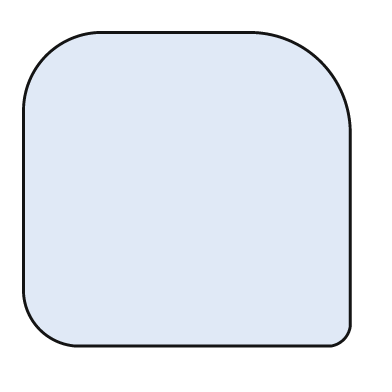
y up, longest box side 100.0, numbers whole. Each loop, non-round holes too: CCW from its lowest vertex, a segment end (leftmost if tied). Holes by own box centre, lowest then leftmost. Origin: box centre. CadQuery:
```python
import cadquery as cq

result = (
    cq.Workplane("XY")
    .moveTo(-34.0, -48.0)
    .lineTo(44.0, -48.0)
    .threePointArc((48.0, -46.0), (50.0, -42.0))
    .lineTo(50.0, 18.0)
    .threePointArc((41.0, 39.0), (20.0, 48.0))
    .lineTo(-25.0, 48.0)
    .threePointArc((-43.0, 41.0), (-50.0, 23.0))
    .lineTo(-50.0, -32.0)
    .threePointArc((-45.0, -43.0), (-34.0, -48.0))
    .close()
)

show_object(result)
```